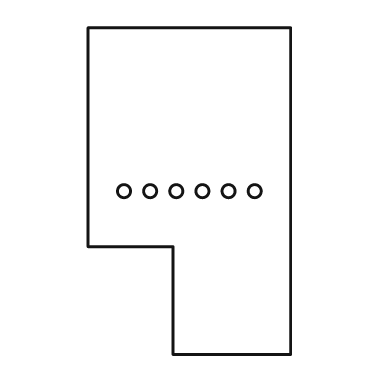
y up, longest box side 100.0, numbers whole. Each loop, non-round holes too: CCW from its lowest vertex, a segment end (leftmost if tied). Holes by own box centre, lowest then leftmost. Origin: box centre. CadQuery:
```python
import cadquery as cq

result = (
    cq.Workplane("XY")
    .moveTo(-5.0, -50.0)
    .lineTo(31.0, -50.0)
    .lineTo(31.0, 50.0)
    .lineTo(-31.0, 50.0)
    .lineTo(-31.0, -17.0)
    .lineTo(-5.0, -17.0)
    .close()
    .moveTo(-20.0, 0.0)
    .circle(2.0)
    .moveTo(-12.0, 0.0)
    .circle(2.0)
    .moveTo(-4.0, 0.0)
    .circle(2.0)
    .moveTo(4.0, 0.0)
    .circle(2.0)
    .moveTo(12.0, 0.0)
    .circle(2.0)
    .moveTo(20.0, 0.0)
    .circle(2.0)
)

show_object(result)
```